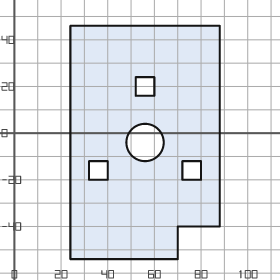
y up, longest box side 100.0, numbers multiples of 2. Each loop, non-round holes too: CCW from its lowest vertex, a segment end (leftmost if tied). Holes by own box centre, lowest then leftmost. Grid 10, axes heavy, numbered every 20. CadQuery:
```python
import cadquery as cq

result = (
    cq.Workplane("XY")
    .moveTo(24.0, -54.0)
    .lineTo(70.0, -54.0)
    .lineTo(70.0, -40.0)
    .lineTo(88.0, -40.0)
    .lineTo(88.0, 46.0)
    .lineTo(24.0, 46.0)
    .close()
    .moveTo(32.0, -20.0)
    .lineTo(40.0, -20.0)
    .lineTo(40.0, -12.0)
    .lineTo(32.0, -12.0)
    .close()
    .moveTo(72.0, -20.0)
    .lineTo(80.0, -20.0)
    .lineTo(80.0, -12.0)
    .lineTo(72.0, -12.0)
    .close()
    .moveTo(56.0, -4.0)
    .circle(8.0)
    .moveTo(52.0, 16.0)
    .lineTo(60.0, 16.0)
    .lineTo(60.0, 24.0)
    .lineTo(52.0, 24.0)
    .close()
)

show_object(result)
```